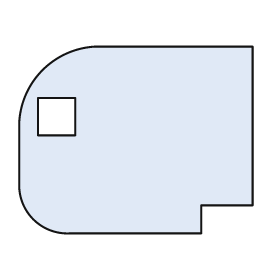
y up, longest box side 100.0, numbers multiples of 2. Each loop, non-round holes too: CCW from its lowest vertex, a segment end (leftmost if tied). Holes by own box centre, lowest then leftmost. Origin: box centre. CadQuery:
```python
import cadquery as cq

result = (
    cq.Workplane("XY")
    .moveTo(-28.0, -40.0)
    .lineTo(28.0, -40.0)
    .lineTo(28.0, -28.0)
    .lineTo(50.0, -28.0)
    .lineTo(50.0, 40.0)
    .lineTo(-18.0, 40.0)
    .threePointArc((-40.0, 30.0), (-50.0, 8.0))
    .lineTo(-50.0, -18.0)
    .threePointArc((-44.0, -34.0), (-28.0, -40.0))
    .close()
    .moveTo(-42.0, 2.0)
    .lineTo(-26.0, 2.0)
    .lineTo(-26.0, 18.0)
    .lineTo(-42.0, 18.0)
    .close()
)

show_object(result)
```